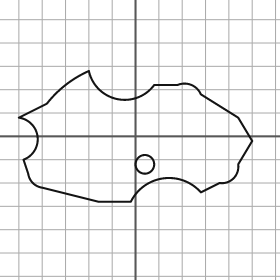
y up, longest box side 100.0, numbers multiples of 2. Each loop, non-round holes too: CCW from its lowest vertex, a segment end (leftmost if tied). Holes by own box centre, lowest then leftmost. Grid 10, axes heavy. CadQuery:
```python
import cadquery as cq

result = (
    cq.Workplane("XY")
    .moveTo(-16.0, -28.0)
    .lineTo(-2.0, -28.0)
    .threePointArc((12.0, -18.0), (28.0, -24.0))
    .lineTo(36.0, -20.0)
    .threePointArc((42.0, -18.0), (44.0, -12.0))
    .lineTo(50.0, -2.0)
    .lineTo(44.0, 8.0)
    .lineTo(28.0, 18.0)
    .threePointArc((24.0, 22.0), (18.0, 22.0))
    .lineTo(8.0, 22.0)
    .threePointArc((-8.0, 16.0), (-20.0, 28.0))
    .threePointArc((-30.0, 22.0), (-38.0, 14.0))
    .lineTo(-50.0, 8.0)
    .threePointArc((-42.0, 0.0), (-48.0, -10.0))
    .lineTo(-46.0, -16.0)
    .threePointArc((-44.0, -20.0), (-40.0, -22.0))
    .close()
    .moveTo(4.0, -12.0)
    .circle(4.0)
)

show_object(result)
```